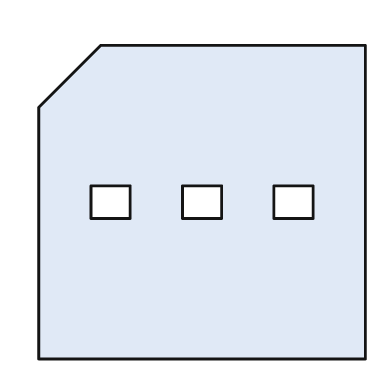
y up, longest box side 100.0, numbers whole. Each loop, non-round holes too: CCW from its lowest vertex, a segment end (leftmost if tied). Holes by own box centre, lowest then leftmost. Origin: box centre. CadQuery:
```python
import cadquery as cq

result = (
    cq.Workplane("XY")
    .moveTo(-50.0, -48.0)
    .lineTo(50.0, -48.0)
    .lineTo(50.0, 48.0)
    .lineTo(-31.0, 48.0)
    .lineTo(-50.0, 29.0)
    .close()
    .moveTo(-34.0, -5.0)
    .lineTo(-22.0, -5.0)
    .lineTo(-22.0, 5.0)
    .lineTo(-34.0, 5.0)
    .close()
    .moveTo(-6.0, -5.0)
    .lineTo(6.0, -5.0)
    .lineTo(6.0, 5.0)
    .lineTo(-6.0, 5.0)
    .close()
    .moveTo(22.0, -5.0)
    .lineTo(34.0, -5.0)
    .lineTo(34.0, 5.0)
    .lineTo(22.0, 5.0)
    .close()
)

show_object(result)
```